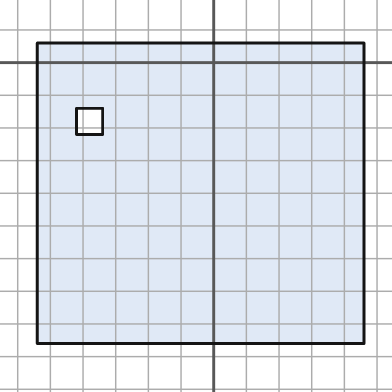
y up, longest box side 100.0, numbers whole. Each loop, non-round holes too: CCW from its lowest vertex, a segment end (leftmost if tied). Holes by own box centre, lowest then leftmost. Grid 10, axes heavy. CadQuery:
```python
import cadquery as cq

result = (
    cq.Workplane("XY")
    .moveTo(-54.0, -86.0)
    .lineTo(46.0, -86.0)
    .lineTo(46.0, 6.0)
    .lineTo(-54.0, 6.0)
    .close()
    .moveTo(-42.0, -22.0)
    .lineTo(-34.0, -22.0)
    .lineTo(-34.0, -14.0)
    .lineTo(-42.0, -14.0)
    .close()
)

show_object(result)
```